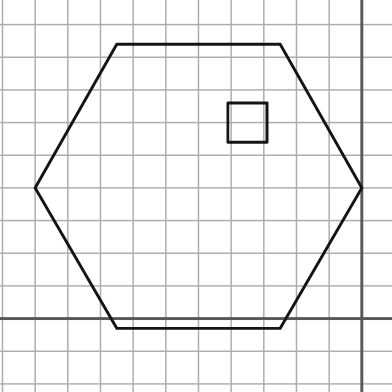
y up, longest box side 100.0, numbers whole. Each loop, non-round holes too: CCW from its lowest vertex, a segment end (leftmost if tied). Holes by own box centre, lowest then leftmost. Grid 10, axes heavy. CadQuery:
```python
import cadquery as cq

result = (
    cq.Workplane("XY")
    .moveTo(-75.0, -3.0)
    .lineTo(-25.0, -3.0)
    .lineTo(0.0, 40.0)
    .lineTo(-25.0, 84.0)
    .lineTo(-75.0, 84.0)
    .lineTo(-100.0, 40.0)
    .close()
    .moveTo(-41.0, 54.0)
    .lineTo(-29.0, 54.0)
    .lineTo(-29.0, 66.0)
    .lineTo(-41.0, 66.0)
    .close()
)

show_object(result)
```